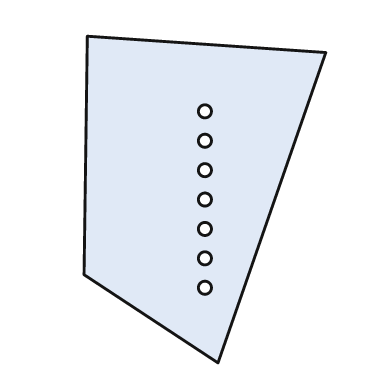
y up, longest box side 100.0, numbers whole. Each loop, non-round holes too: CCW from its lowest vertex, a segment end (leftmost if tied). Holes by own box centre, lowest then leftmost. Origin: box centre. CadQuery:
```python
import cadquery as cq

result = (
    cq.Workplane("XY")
    .moveTo(4.0, -50.0)
    .lineTo(37.0, 45.0)
    .lineTo(-36.0, 50.0)
    .lineTo(-37.0, -23.0)
    .close()
    .moveTo(0.0, -27.0)
    .circle(2.0)
    .moveTo(0.0, -18.0)
    .circle(2.0)
    .moveTo(0.0, -9.0)
    .circle(2.0)
    .moveTo(0.0, 0.0)
    .circle(2.0)
    .moveTo(0.0, 9.0)
    .circle(2.0)
    .moveTo(0.0, 18.0)
    .circle(2.0)
    .moveTo(0.0, 27.0)
    .circle(2.0)
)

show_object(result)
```